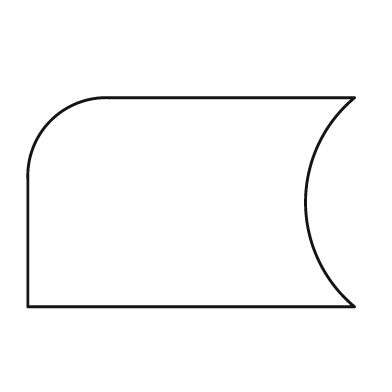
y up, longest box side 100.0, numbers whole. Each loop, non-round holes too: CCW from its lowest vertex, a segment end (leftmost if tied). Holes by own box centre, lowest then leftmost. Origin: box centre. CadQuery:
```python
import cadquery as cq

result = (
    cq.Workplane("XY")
    .moveTo(-50.0, -32.0)
    .lineTo(50.0, -32.0)
    .threePointArc((35.0, 0.0), (50.0, 32.0))
    .lineTo(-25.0, 32.0)
    .threePointArc((-43.0, 25.0), (-50.0, 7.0))
    .close()
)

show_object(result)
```